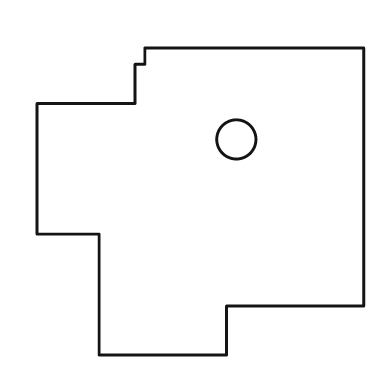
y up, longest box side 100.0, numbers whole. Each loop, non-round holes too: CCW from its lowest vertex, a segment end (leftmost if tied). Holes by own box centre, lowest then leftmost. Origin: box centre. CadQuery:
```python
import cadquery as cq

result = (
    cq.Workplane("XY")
    .moveTo(-31.0, -47.0)
    .lineTo(8.0, -47.0)
    .lineTo(8.0, -32.0)
    .lineTo(50.0, -32.0)
    .lineTo(50.0, 47.0)
    .lineTo(-17.0, 47.0)
    .lineTo(-17.0, 42.0)
    .lineTo(-20.0, 42.0)
    .lineTo(-20.0, 30.0)
    .lineTo(-50.0, 30.0)
    .lineTo(-50.0, -10.0)
    .lineTo(-31.0, -10.0)
    .close()
    .moveTo(11.0, 19.0)
    .circle(6.0)
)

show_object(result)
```